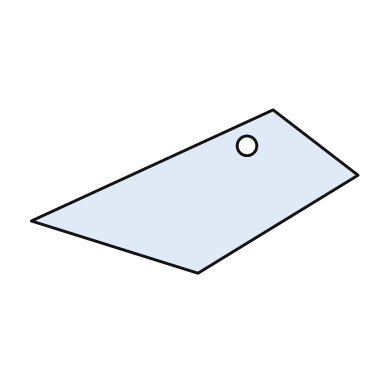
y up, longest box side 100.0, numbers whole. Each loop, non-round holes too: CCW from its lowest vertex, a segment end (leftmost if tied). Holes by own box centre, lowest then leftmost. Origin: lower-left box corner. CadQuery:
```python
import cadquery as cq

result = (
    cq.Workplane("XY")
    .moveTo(51.0, 0.0)
    .lineTo(100.0, 30.0)
    .lineTo(74.0, 50.0)
    .lineTo(0.0, 16.0)
    .close()
    .moveTo(66.0, 39.0)
    .circle(3.0)
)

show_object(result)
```